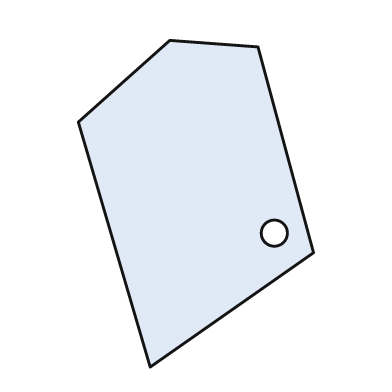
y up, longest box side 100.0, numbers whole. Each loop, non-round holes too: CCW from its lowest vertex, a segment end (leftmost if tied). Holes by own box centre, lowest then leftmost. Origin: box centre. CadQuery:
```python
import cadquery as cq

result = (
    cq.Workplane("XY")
    .moveTo(-14.0, -50.0)
    .lineTo(36.0, -15.0)
    .lineTo(19.0, 48.0)
    .lineTo(-8.0, 50.0)
    .lineTo(-36.0, 25.0)
    .close()
    .moveTo(24.0, -9.0)
    .circle(4.0)
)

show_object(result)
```